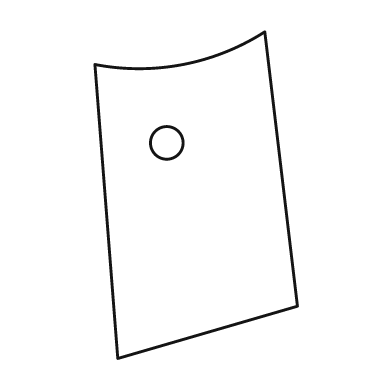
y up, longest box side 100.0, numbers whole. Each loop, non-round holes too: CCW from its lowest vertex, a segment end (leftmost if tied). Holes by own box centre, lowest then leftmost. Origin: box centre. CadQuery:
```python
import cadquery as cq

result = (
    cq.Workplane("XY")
    .moveTo(-24.0, -50.0)
    .lineTo(31.0, -34.0)
    .lineTo(21.0, 50.0)
    .threePointArc((-4.0, 40.0), (-31.0, 40.0))
    .close()
    .moveTo(-9.0, 16.0)
    .circle(5.0)
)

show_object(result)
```